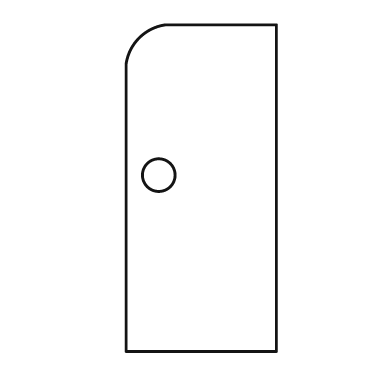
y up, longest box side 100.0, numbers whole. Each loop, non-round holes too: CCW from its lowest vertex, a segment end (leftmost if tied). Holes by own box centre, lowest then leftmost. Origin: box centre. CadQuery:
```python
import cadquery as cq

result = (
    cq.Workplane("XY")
    .moveTo(-23.0, -50.0)
    .lineTo(23.0, -50.0)
    .lineTo(23.0, 50.0)
    .lineTo(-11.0, 50.0)
    .threePointArc((-19.0, 46.0), (-23.0, 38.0))
    .close()
    .moveTo(-13.0, 4.0)
    .circle(5.0)
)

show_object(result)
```